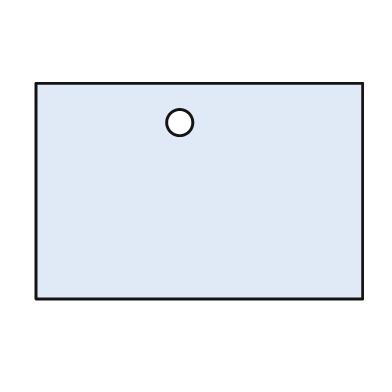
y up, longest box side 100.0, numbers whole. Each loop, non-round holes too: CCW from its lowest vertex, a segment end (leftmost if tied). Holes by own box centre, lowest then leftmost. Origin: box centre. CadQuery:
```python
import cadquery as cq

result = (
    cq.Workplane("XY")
    .moveTo(-50.0, -33.0)
    .lineTo(50.0, -33.0)
    .lineTo(50.0, 33.0)
    .lineTo(-50.0, 33.0)
    .close()
    .moveTo(-6.0, 21.0)
    .circle(4.0)
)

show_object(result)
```